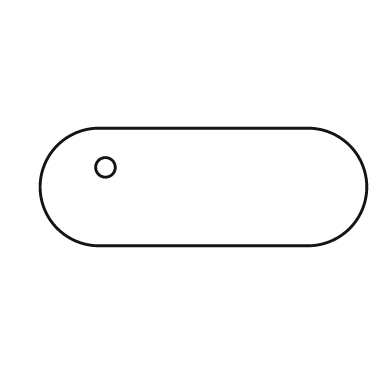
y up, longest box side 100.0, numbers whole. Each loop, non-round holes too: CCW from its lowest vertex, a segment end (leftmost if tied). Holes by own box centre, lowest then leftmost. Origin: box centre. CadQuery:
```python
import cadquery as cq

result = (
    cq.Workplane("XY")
    .moveTo(-32.0, -18.0)
    .lineTo(32.0, -18.0)
    .threePointArc((50.0, 0.0), (32.0, 18.0))
    .lineTo(-32.0, 18.0)
    .threePointArc((-50.0, 0.0), (-32.0, -18.0))
    .close()
    .moveTo(-30.0, 6.0)
    .circle(3.0)
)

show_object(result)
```